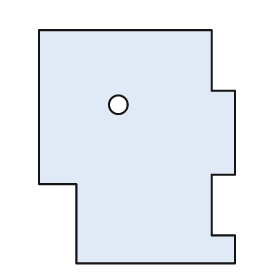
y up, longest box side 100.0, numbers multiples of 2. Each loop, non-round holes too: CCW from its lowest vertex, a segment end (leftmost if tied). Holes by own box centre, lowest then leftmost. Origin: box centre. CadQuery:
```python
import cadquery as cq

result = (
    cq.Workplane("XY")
    .moveTo(-26.0, -50.0)
    .lineTo(42.0, -50.0)
    .lineTo(42.0, -38.0)
    .lineTo(32.0, -38.0)
    .lineTo(32.0, -12.0)
    .lineTo(42.0, -12.0)
    .lineTo(42.0, 24.0)
    .lineTo(32.0, 24.0)
    .lineTo(32.0, 50.0)
    .lineTo(-42.0, 50.0)
    .lineTo(-42.0, -16.0)
    .lineTo(-26.0, -16.0)
    .close()
    .moveTo(-8.0, 18.0)
    .circle(4.0)
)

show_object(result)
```